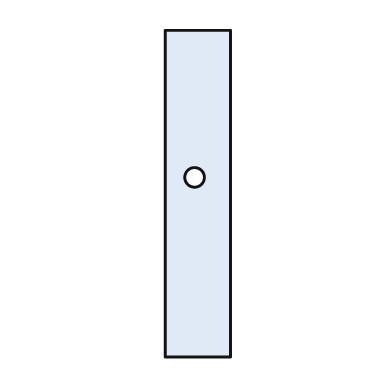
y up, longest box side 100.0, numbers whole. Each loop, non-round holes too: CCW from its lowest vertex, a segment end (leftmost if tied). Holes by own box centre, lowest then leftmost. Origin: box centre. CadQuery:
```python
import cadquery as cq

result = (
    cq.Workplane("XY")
    .moveTo(-10.0, -50.0)
    .lineTo(10.0, -50.0)
    .lineTo(10.0, 50.0)
    .lineTo(-10.0, 50.0)
    .close()
    .moveTo(-1.0, 5.0)
    .circle(3.0)
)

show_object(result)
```